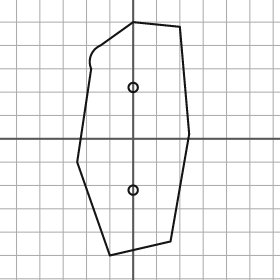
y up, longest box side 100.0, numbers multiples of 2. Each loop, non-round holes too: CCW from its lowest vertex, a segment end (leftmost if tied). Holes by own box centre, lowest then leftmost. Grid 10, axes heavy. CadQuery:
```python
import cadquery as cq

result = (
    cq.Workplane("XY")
    .moveTo(-10.0, -50.0)
    .lineTo(16.0, -44.0)
    .lineTo(24.0, 2.0)
    .lineTo(20.0, 48.0)
    .lineTo(0.0, 50.0)
    .lineTo(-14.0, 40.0)
    .threePointArc((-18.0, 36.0), (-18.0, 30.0))
    .lineTo(-24.0, -10.0)
    .close()
    .moveTo(0.0, -22.0)
    .circle(2.0)
    .moveTo(0.0, 22.0)
    .circle(2.0)
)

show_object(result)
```